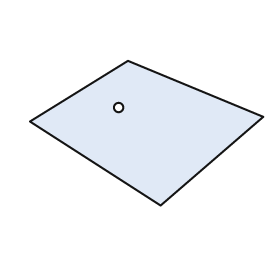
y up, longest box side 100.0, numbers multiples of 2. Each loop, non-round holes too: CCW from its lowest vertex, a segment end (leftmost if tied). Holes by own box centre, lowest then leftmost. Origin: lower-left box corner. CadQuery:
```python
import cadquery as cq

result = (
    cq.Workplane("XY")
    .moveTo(56.0, 0.0)
    .lineTo(100.0, 38.0)
    .lineTo(42.0, 62.0)
    .lineTo(0.0, 36.0)
    .close()
    .moveTo(38.0, 42.0)
    .circle(2.0)
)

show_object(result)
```